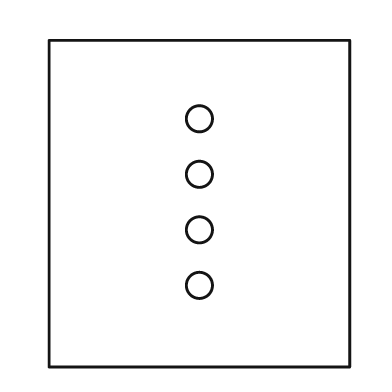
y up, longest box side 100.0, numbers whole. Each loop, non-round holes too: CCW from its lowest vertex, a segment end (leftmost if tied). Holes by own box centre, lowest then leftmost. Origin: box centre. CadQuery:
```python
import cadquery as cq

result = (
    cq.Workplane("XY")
    .moveTo(-46.0, -50.0)
    .lineTo(46.0, -50.0)
    .lineTo(46.0, 50.0)
    .lineTo(-46.0, 50.0)
    .close()
    .moveTo(0.0, -25.0)
    .circle(4.0)
    .moveTo(0.0, -8.0)
    .circle(4.0)
    .moveTo(0.0, 9.0)
    .circle(4.0)
    .moveTo(0.0, 26.0)
    .circle(4.0)
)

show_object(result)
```